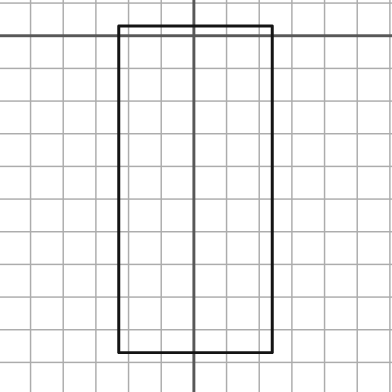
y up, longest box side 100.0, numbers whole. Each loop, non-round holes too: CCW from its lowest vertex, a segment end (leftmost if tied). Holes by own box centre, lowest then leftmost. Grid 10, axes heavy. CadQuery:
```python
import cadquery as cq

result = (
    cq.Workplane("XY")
    .moveTo(-23.0, -97.0)
    .lineTo(24.0, -97.0)
    .lineTo(24.0, 3.0)
    .lineTo(-23.0, 3.0)
    .close()
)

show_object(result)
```